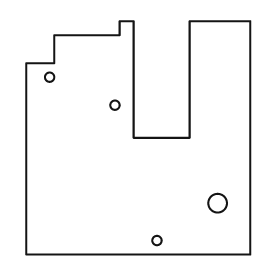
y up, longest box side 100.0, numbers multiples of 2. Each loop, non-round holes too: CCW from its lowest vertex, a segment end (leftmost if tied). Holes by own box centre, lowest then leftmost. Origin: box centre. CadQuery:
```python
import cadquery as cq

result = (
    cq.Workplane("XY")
    .moveTo(-48.0, -50.0)
    .lineTo(48.0, -50.0)
    .lineTo(48.0, 50.0)
    .lineTo(22.0, 50.0)
    .lineTo(22.0, 0.0)
    .lineTo(-2.0, 0.0)
    .lineTo(-2.0, 50.0)
    .lineTo(-8.0, 50.0)
    .lineTo(-8.0, 44.0)
    .lineTo(-36.0, 44.0)
    .lineTo(-36.0, 32.0)
    .lineTo(-48.0, 32.0)
    .close()
    .moveTo(8.0, -44.0)
    .circle(2.0)
    .moveTo(34.0, -28.0)
    .circle(4.0)
    .moveTo(-10.0, 14.0)
    .circle(2.0)
    .moveTo(-38.0, 26.0)
    .circle(2.0)
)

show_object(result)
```